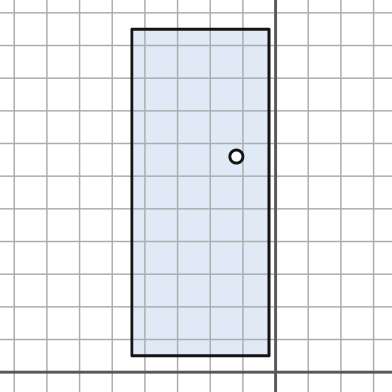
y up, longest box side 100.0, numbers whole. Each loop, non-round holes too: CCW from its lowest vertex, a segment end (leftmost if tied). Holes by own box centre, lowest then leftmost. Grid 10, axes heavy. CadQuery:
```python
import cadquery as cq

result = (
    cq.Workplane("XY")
    .moveTo(-44.0, 5.0)
    .lineTo(-2.0, 5.0)
    .lineTo(-2.0, 105.0)
    .lineTo(-44.0, 105.0)
    .close()
    .moveTo(-12.0, 66.0)
    .circle(2.0)
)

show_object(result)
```